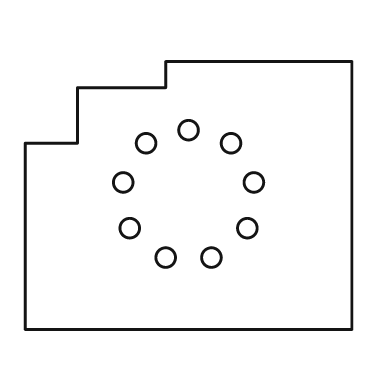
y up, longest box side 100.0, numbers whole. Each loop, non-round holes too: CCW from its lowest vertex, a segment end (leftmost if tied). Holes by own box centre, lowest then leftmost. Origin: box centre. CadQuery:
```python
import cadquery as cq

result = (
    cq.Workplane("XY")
    .moveTo(-50.0, -41.0)
    .lineTo(50.0, -41.0)
    .lineTo(50.0, 41.0)
    .lineTo(-7.0, 41.0)
    .lineTo(-7.0, 33.0)
    .lineTo(-34.0, 33.0)
    .lineTo(-34.0, 16.0)
    .lineTo(-50.0, 16.0)
    .close()
    .moveTo(-7.0, -19.0)
    .circle(3.0)
    .moveTo(7.0, -19.0)
    .circle(3.0)
    .moveTo(-18.0, -10.0)
    .circle(3.0)
    .moveTo(18.0, -10.0)
    .circle(3.0)
    .moveTo(-20.0, 4.0)
    .circle(3.0)
    .moveTo(20.0, 4.0)
    .circle(3.0)
    .moveTo(-13.0, 16.0)
    .circle(3.0)
    .moveTo(13.0, 16.0)
    .circle(3.0)
    .moveTo(0.0, 20.0)
    .circle(3.0)
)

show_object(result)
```